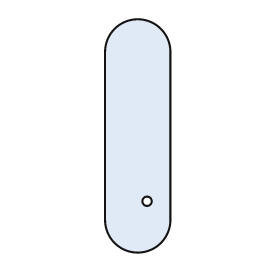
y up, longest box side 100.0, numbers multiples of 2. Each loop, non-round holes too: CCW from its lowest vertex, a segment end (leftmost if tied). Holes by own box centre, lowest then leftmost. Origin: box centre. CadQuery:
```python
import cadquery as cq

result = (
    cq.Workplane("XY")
    .moveTo(-14.0, -36.0)
    .threePointArc((0.0, -50.0), (14.0, -36.0))
    .lineTo(14.0, 36.0)
    .threePointArc((0.0, 50.0), (-14.0, 36.0))
    .close()
    .moveTo(4.0, -28.0)
    .circle(2.0)
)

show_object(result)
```